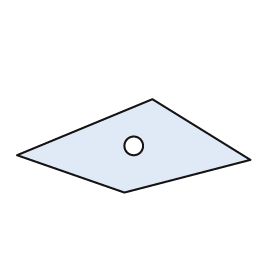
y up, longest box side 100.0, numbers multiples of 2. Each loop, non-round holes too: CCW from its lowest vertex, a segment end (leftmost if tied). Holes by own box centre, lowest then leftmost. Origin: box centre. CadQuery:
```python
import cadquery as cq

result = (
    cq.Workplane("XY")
    .moveTo(-4.0, -20.0)
    .lineTo(50.0, -6.0)
    .lineTo(8.0, 20.0)
    .lineTo(-50.0, -4.0)
    .close()
    .moveTo(0.0, 0.0)
    .circle(4.0)
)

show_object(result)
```